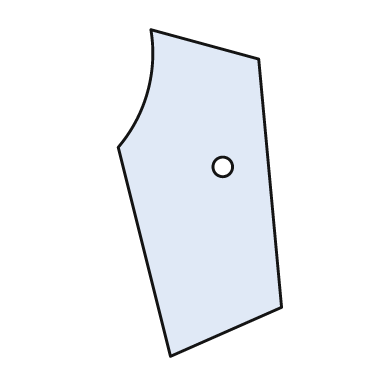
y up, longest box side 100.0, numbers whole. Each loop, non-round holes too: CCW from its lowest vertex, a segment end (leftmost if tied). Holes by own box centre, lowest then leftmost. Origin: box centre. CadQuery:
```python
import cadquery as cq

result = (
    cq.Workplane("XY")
    .moveTo(-9.0, -50.0)
    .lineTo(25.0, -35.0)
    .lineTo(18.0, 41.0)
    .lineTo(-15.0, 50.0)
    .threePointArc((-16.0, 31.0), (-25.0, 14.0))
    .close()
    .moveTo(7.0, 8.0)
    .circle(3.0)
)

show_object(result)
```